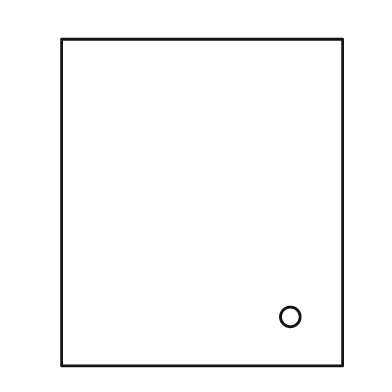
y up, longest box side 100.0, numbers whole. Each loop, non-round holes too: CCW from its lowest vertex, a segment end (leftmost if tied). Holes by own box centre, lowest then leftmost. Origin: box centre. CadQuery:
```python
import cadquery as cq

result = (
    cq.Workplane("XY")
    .moveTo(-43.0, -50.0)
    .lineTo(43.0, -50.0)
    .lineTo(43.0, 50.0)
    .lineTo(-43.0, 50.0)
    .close()
    .moveTo(27.0, -35.0)
    .circle(3.0)
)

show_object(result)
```